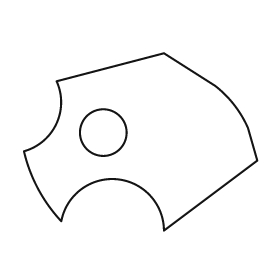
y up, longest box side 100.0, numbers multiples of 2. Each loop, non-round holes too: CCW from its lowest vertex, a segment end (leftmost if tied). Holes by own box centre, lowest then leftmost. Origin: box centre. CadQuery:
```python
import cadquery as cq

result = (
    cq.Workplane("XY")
    .moveTo(10.0, -38.0)
    .lineTo(50.0, -8.0)
    .lineTo(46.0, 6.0)
    .threePointArc((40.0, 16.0), (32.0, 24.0))
    .lineTo(10.0, 38.0)
    .lineTo(-36.0, 26.0)
    .threePointArc((-36.0, 8.0), (-50.0, -4.0))
    .threePointArc((-44.0, -20.0), (-34.0, -34.0))
    .threePointArc((-10.0, -16.0), (10.0, -38.0))
    .close()
    .moveTo(-16.0, 4.0)
    .circle(10.0)
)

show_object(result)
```